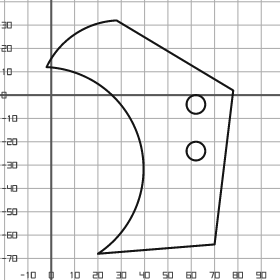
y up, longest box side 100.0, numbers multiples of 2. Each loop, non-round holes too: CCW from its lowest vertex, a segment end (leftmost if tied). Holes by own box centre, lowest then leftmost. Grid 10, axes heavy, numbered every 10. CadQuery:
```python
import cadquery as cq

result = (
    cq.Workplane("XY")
    .moveTo(20.0, -68.0)
    .lineTo(70.0, -64.0)
    .lineTo(78.0, 2.0)
    .lineTo(28.0, 32.0)
    .threePointArc((10.0, 26.0), (-2.0, 12.0))
    .threePointArc((38.0, -20.0), (20.0, -68.0))
    .close()
    .moveTo(62.0, -24.0)
    .circle(4.0)
    .moveTo(62.0, -4.0)
    .circle(4.0)
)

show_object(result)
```